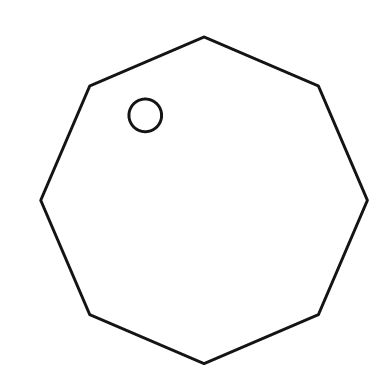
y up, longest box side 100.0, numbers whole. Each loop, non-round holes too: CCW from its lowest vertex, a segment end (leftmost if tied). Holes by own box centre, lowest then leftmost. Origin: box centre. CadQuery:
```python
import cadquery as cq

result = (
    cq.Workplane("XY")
    .moveTo(0.0, -50.0)
    .lineTo(35.0, -35.0)
    .lineTo(50.0, 0.0)
    .lineTo(35.0, 35.0)
    .lineTo(0.0, 50.0)
    .lineTo(-35.0, 35.0)
    .lineTo(-50.0, 0.0)
    .lineTo(-35.0, -35.0)
    .close()
    .moveTo(-18.0, 26.0)
    .circle(5.0)
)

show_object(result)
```